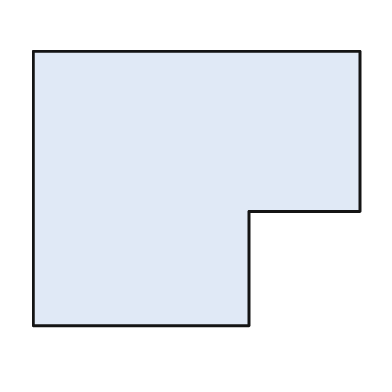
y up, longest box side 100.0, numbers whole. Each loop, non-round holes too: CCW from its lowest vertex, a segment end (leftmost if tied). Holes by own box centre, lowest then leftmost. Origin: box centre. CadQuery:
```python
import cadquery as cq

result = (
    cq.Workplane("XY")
    .moveTo(-50.0, -42.0)
    .lineTo(16.0, -42.0)
    .lineTo(16.0, -7.0)
    .lineTo(50.0, -7.0)
    .lineTo(50.0, 42.0)
    .lineTo(-50.0, 42.0)
    .close()
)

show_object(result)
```